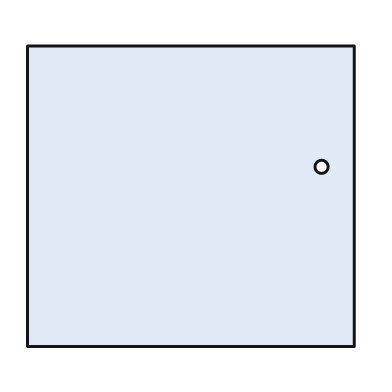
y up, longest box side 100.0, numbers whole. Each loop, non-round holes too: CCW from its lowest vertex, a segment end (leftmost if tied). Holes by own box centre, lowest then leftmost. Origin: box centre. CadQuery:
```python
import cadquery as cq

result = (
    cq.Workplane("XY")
    .moveTo(-50.0, -46.0)
    .lineTo(50.0, -46.0)
    .lineTo(50.0, 46.0)
    .lineTo(-50.0, 46.0)
    .close()
    .moveTo(40.0, 9.0)
    .circle(2.0)
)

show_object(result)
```